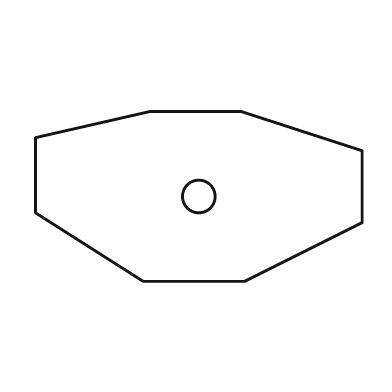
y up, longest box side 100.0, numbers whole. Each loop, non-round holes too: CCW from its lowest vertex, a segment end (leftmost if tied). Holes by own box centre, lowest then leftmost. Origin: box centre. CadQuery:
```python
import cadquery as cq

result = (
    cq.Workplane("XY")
    .moveTo(-17.0, -26.0)
    .lineTo(14.0, -26.0)
    .lineTo(50.0, -8.0)
    .lineTo(50.0, 14.0)
    .lineTo(13.0, 26.0)
    .lineTo(-15.0, 26.0)
    .lineTo(-50.0, 18.0)
    .lineTo(-50.0, -5.0)
    .close()
    .moveTo(0.0, 0.0)
    .circle(5.0)
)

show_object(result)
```